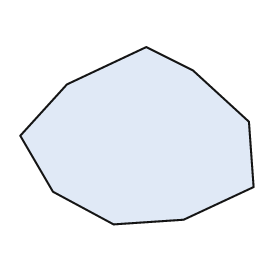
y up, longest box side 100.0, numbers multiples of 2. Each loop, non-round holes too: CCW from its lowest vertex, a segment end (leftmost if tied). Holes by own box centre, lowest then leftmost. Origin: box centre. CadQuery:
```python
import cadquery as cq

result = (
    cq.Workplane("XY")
    .moveTo(-10.0, -38.0)
    .lineTo(20.0, -36.0)
    .lineTo(50.0, -22.0)
    .lineTo(48.0, 6.0)
    .lineTo(24.0, 28.0)
    .lineTo(4.0, 38.0)
    .lineTo(-30.0, 22.0)
    .lineTo(-50.0, 0.0)
    .lineTo(-36.0, -24.0)
    .close()
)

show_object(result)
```